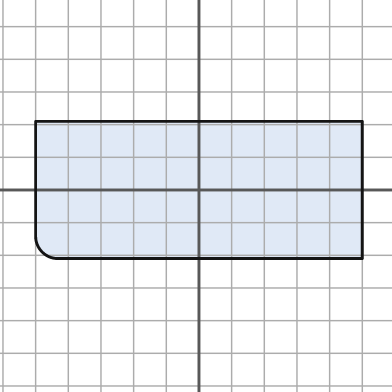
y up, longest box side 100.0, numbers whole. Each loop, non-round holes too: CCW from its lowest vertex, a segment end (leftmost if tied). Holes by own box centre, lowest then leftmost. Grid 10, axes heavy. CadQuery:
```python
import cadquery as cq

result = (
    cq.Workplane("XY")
    .moveTo(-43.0, -21.0)
    .lineTo(50.0, -21.0)
    .lineTo(50.0, 21.0)
    .lineTo(-50.0, 21.0)
    .lineTo(-50.0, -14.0)
    .threePointArc((-48.0, -19.0), (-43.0, -21.0))
    .close()
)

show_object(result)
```